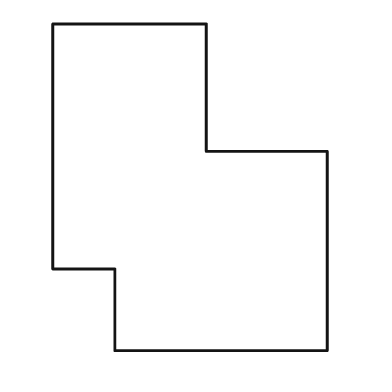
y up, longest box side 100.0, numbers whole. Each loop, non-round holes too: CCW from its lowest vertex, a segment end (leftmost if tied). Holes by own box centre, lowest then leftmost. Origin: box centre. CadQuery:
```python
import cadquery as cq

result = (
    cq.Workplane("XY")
    .moveTo(-23.0, -50.0)
    .lineTo(42.0, -50.0)
    .lineTo(42.0, 11.0)
    .lineTo(5.0, 11.0)
    .lineTo(5.0, 50.0)
    .lineTo(-42.0, 50.0)
    .lineTo(-42.0, -25.0)
    .lineTo(-23.0, -25.0)
    .close()
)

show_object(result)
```